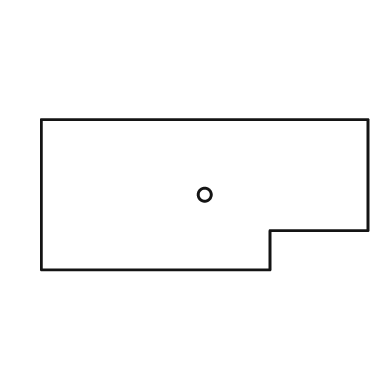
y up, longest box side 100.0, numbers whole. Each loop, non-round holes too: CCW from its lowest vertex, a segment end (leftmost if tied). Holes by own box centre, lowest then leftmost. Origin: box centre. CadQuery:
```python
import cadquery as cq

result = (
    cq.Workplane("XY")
    .moveTo(-50.0, -23.0)
    .lineTo(20.0, -23.0)
    .lineTo(20.0, -11.0)
    .lineTo(50.0, -11.0)
    .lineTo(50.0, 23.0)
    .lineTo(-50.0, 23.0)
    .close()
    .moveTo(0.0, 0.0)
    .circle(2.0)
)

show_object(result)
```